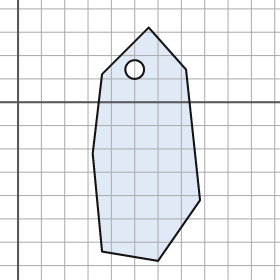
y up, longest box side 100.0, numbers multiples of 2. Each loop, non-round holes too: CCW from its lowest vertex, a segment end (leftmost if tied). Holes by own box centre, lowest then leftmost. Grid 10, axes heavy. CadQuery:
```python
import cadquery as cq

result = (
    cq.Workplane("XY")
    .moveTo(60.0, -68.0)
    .lineTo(78.0, -42.0)
    .lineTo(72.0, 14.0)
    .lineTo(56.0, 32.0)
    .lineTo(36.0, 12.0)
    .lineTo(32.0, -22.0)
    .lineTo(36.0, -64.0)
    .close()
    .moveTo(50.0, 14.0)
    .circle(4.0)
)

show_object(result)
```